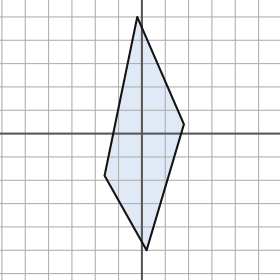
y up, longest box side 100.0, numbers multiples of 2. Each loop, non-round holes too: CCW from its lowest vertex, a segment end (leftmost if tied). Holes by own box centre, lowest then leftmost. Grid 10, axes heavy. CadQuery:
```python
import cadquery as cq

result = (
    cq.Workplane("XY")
    .moveTo(2.0, -50.0)
    .lineTo(18.0, 4.0)
    .lineTo(-2.0, 50.0)
    .lineTo(-16.0, -18.0)
    .close()
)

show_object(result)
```